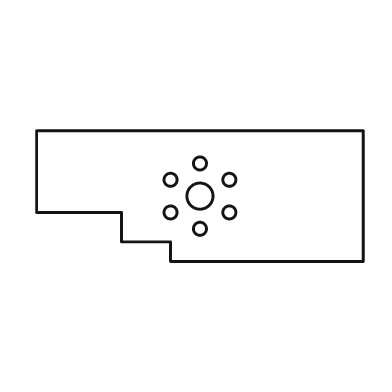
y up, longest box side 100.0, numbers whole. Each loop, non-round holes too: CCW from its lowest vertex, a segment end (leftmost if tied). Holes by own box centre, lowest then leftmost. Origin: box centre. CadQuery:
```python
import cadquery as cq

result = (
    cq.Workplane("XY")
    .moveTo(-9.0, -20.0)
    .lineTo(50.0, -20.0)
    .lineTo(50.0, 20.0)
    .lineTo(-50.0, 20.0)
    .lineTo(-50.0, -5.0)
    .lineTo(-24.0, -5.0)
    .lineTo(-24.0, -14.0)
    .lineTo(-9.0, -14.0)
    .close()
    .moveTo(0.0, -10.0)
    .circle(2.0)
    .moveTo(-9.0, -5.0)
    .circle(2.0)
    .moveTo(9.0, -5.0)
    .circle(2.0)
    .moveTo(0.0, 0.0)
    .circle(4.0)
    .moveTo(-9.0, 5.0)
    .circle(2.0)
    .moveTo(9.0, 5.0)
    .circle(2.0)
    .moveTo(0.0, 10.0)
    .circle(2.0)
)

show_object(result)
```